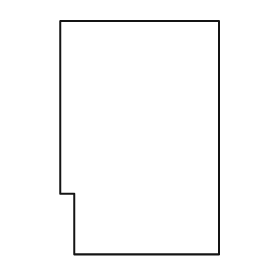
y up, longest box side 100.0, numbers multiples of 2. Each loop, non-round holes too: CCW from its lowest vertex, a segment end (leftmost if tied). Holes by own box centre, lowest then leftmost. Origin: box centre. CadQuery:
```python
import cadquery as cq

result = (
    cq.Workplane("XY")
    .moveTo(-28.0, -50.0)
    .lineTo(34.0, -50.0)
    .lineTo(34.0, 50.0)
    .lineTo(-34.0, 50.0)
    .lineTo(-34.0, -24.0)
    .lineTo(-28.0, -24.0)
    .close()
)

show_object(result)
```